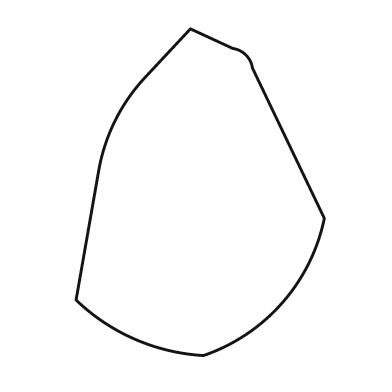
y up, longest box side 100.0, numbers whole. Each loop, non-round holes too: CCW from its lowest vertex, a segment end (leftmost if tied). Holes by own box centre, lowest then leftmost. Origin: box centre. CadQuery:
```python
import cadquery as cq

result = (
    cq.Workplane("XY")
    .moveTo(1.0, -50.0)
    .threePointArc((25.0, -34.0), (38.0, -8.0))
    .lineTo(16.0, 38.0)
    .threePointArc((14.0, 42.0), (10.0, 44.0))
    .lineTo(-3.0, 50.0)
    .lineTo(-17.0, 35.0)
    .threePointArc((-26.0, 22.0), (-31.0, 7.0))
    .lineTo(-38.0, -33.0)
    .threePointArc((-20.0, -45.0), (1.0, -50.0))
    .close()
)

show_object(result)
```